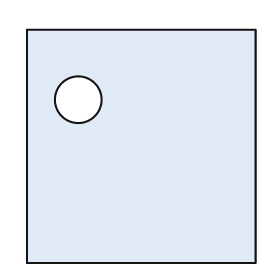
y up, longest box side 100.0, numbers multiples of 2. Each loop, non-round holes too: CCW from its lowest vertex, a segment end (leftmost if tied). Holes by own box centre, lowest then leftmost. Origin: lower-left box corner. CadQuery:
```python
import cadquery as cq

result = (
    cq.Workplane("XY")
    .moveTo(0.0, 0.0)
    .lineTo(98.0, 0.0)
    .lineTo(98.0, 100.0)
    .lineTo(0.0, 100.0)
    .close()
    .moveTo(22.0, 70.0)
    .circle(10.0)
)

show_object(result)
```